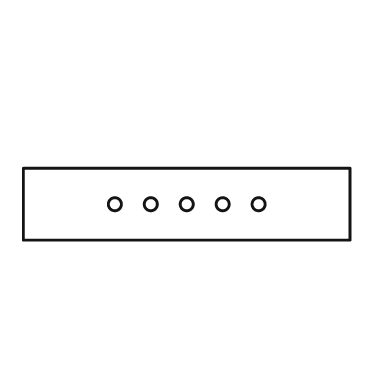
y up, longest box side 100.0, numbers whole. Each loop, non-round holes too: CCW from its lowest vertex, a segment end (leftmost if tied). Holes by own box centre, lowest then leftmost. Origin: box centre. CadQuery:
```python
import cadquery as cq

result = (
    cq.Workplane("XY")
    .moveTo(-50.0, -11.0)
    .lineTo(50.0, -11.0)
    .lineTo(50.0, 11.0)
    .lineTo(-50.0, 11.0)
    .close()
    .moveTo(-22.0, 0.0)
    .circle(2.0)
    .moveTo(-11.0, 0.0)
    .circle(2.0)
    .moveTo(0.0, 0.0)
    .circle(2.0)
    .moveTo(11.0, 0.0)
    .circle(2.0)
    .moveTo(22.0, 0.0)
    .circle(2.0)
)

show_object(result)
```